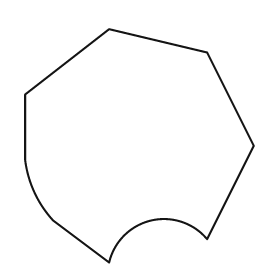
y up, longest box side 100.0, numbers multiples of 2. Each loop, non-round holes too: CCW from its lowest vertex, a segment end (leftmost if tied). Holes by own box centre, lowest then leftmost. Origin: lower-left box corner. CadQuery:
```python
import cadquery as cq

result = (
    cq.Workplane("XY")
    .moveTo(36.0, 0.0)
    .threePointArc((54.0, 18.0), (78.0, 10.0))
    .lineTo(98.0, 50.0)
    .lineTo(78.0, 90.0)
    .lineTo(36.0, 100.0)
    .lineTo(0.0, 72.0)
    .lineTo(0.0, 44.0)
    .threePointArc((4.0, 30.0), (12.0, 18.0))
    .close()
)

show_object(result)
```